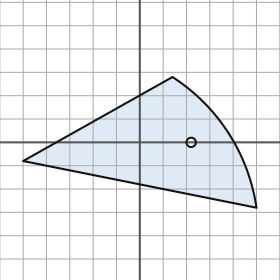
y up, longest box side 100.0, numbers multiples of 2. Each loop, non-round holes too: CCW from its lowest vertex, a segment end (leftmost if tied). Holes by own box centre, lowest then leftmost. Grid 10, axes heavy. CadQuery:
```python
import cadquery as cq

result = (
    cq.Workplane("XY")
    .moveTo(50.0, -28.0)
    .threePointArc((38.0, 4.0), (14.0, 28.0))
    .lineTo(-50.0, -8.0)
    .close()
    .moveTo(22.0, 0.0)
    .circle(2.0)
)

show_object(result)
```